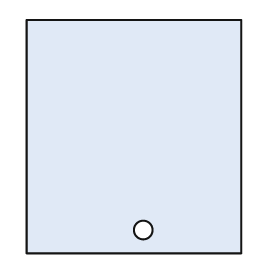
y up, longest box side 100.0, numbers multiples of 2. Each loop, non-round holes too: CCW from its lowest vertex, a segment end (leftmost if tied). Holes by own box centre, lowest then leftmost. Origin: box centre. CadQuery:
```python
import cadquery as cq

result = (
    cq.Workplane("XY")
    .moveTo(-46.0, -50.0)
    .lineTo(46.0, -50.0)
    .lineTo(46.0, 50.0)
    .lineTo(-46.0, 50.0)
    .close()
    .moveTo(4.0, -40.0)
    .circle(4.0)
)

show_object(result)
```